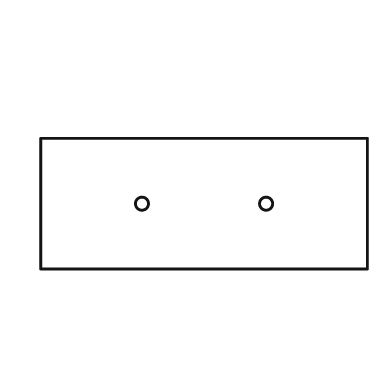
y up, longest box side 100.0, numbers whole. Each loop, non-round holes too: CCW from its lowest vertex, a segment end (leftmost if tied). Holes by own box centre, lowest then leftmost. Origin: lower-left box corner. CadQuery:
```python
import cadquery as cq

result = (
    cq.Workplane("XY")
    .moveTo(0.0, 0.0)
    .lineTo(100.0, 0.0)
    .lineTo(100.0, 40.0)
    .lineTo(0.0, 40.0)
    .close()
    .moveTo(31.0, 20.0)
    .circle(2.0)
    .moveTo(69.0, 20.0)
    .circle(2.0)
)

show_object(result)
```